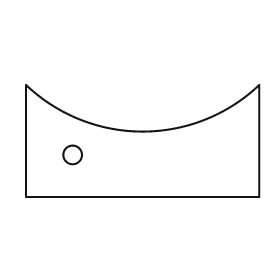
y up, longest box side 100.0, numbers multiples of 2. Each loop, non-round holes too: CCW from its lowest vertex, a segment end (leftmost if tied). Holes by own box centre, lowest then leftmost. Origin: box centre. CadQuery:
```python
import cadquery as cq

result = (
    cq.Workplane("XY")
    .moveTo(-50.0, -24.0)
    .lineTo(50.0, -24.0)
    .lineTo(50.0, 24.0)
    .threePointArc((0.0, 4.0), (-50.0, 24.0))
    .close()
    .moveTo(-30.0, -6.0)
    .circle(4.0)
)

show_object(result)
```